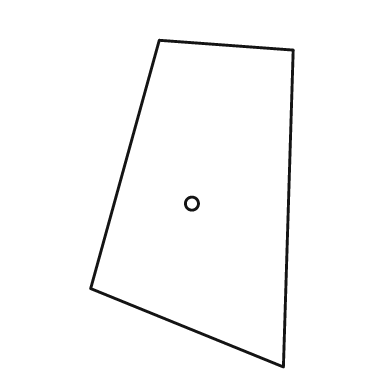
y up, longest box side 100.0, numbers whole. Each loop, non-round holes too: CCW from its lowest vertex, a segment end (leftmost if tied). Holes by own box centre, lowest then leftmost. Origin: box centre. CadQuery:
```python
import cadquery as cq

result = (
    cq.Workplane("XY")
    .moveTo(28.0, -50.0)
    .lineTo(31.0, 47.0)
    .lineTo(-10.0, 50.0)
    .lineTo(-31.0, -26.0)
    .close()
    .moveTo(0.0, 0.0)
    .circle(2.0)
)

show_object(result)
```